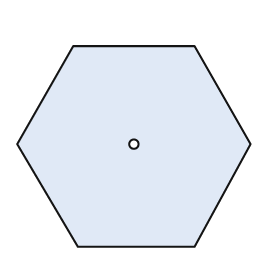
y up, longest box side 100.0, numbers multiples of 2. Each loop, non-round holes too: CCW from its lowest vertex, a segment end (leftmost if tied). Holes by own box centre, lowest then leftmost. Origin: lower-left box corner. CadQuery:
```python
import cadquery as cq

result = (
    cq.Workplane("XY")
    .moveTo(26.0, 0.0)
    .lineTo(76.0, 0.0)
    .lineTo(100.0, 44.0)
    .lineTo(76.0, 86.0)
    .lineTo(24.0, 86.0)
    .lineTo(0.0, 44.0)
    .close()
    .moveTo(50.0, 44.0)
    .circle(2.0)
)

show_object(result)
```